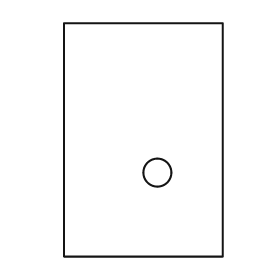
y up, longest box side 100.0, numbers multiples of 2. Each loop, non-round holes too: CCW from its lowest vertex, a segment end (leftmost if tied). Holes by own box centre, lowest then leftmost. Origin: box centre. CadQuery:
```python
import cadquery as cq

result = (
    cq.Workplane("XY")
    .moveTo(-34.0, -50.0)
    .lineTo(34.0, -50.0)
    .lineTo(34.0, 50.0)
    .lineTo(-34.0, 50.0)
    .close()
    .moveTo(6.0, -14.0)
    .circle(6.0)
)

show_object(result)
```